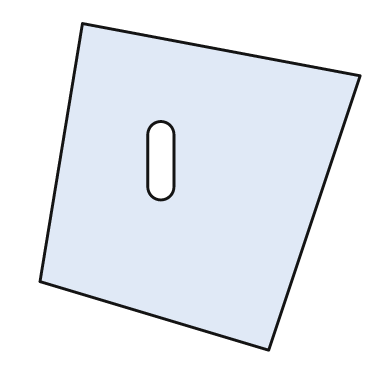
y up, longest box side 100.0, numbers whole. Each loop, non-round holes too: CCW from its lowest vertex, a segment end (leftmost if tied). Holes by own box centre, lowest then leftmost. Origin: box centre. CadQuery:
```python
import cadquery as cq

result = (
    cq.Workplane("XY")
    .moveTo(21.0, -50.0)
    .lineTo(49.0, 34.0)
    .lineTo(-36.0, 50.0)
    .lineTo(-49.0, -29.0)
    .close()
    .moveTo(-16.0, 0.0)
    .threePointArc((-12.0, -4.0), (-8.0, 0.0))
    .lineTo(-8.0, 16.0)
    .threePointArc((-12.0, 20.0), (-16.0, 16.0))
    .close()
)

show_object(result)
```